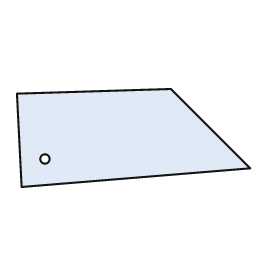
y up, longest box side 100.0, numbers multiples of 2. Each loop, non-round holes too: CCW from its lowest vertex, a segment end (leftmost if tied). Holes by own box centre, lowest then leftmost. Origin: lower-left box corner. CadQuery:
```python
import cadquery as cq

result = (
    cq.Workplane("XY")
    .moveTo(2.0, 0.0)
    .lineTo(100.0, 8.0)
    .lineTo(66.0, 42.0)
    .lineTo(0.0, 40.0)
    .close()
    .moveTo(12.0, 12.0)
    .circle(2.0)
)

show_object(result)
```